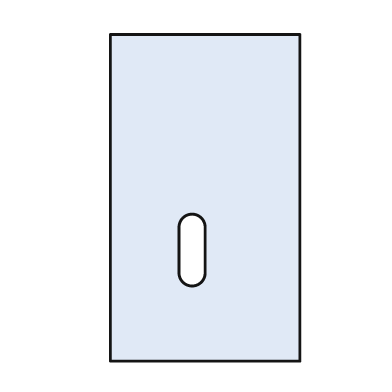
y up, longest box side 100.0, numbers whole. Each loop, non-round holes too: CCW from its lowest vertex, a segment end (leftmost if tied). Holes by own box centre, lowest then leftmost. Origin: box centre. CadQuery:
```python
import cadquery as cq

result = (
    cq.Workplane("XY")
    .moveTo(-29.0, -50.0)
    .lineTo(29.0, -50.0)
    .lineTo(29.0, 50.0)
    .lineTo(-29.0, 50.0)
    .close()
    .moveTo(-8.0, -23.0)
    .threePointArc((-4.0, -27.0), (0.0, -23.0))
    .lineTo(0.0, -9.0)
    .threePointArc((-4.0, -5.0), (-8.0, -9.0))
    .close()
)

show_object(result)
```